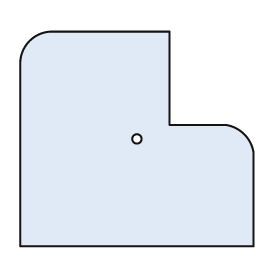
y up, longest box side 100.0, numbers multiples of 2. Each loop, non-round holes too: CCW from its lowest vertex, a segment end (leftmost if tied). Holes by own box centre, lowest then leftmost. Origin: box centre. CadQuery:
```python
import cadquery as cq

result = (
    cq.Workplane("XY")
    .moveTo(-50.0, -46.0)
    .lineTo(50.0, -46.0)
    .lineTo(50.0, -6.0)
    .threePointArc((46.0, 2.0), (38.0, 6.0))
    .lineTo(14.0, 6.0)
    .lineTo(14.0, 46.0)
    .lineTo(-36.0, 46.0)
    .threePointArc((-46.0, 42.0), (-50.0, 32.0))
    .close()
    .moveTo(0.0, 0.0)
    .circle(2.0)
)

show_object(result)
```